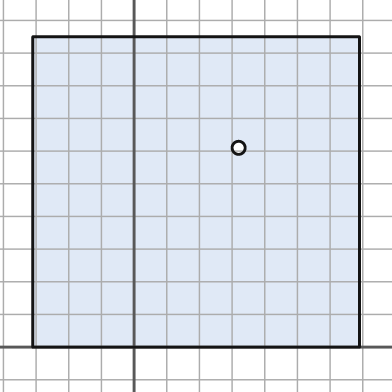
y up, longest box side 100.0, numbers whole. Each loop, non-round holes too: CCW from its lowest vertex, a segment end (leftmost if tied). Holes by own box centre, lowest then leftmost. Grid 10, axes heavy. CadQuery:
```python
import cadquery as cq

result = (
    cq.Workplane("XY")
    .moveTo(-31.0, 0.0)
    .lineTo(69.0, 0.0)
    .lineTo(69.0, 95.0)
    .lineTo(-31.0, 95.0)
    .close()
    .moveTo(32.0, 61.0)
    .circle(2.0)
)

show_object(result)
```